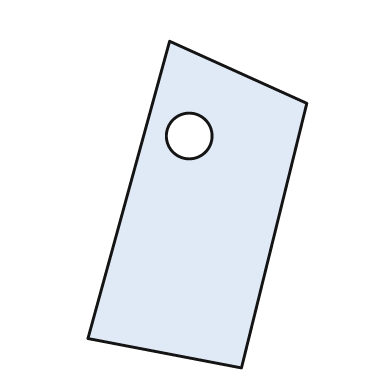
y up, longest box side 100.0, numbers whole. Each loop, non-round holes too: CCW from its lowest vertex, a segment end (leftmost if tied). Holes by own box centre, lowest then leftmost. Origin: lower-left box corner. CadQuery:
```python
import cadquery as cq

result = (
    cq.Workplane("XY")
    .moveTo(47.0, 0.0)
    .lineTo(67.0, 81.0)
    .lineTo(25.0, 100.0)
    .lineTo(0.0, 9.0)
    .close()
    .moveTo(31.0, 71.0)
    .circle(7.0)
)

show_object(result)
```